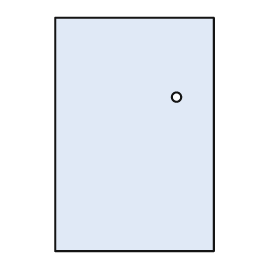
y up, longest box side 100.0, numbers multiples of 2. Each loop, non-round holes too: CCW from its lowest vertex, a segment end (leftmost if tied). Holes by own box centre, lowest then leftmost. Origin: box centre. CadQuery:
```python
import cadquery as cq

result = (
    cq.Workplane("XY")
    .moveTo(-34.0, -50.0)
    .lineTo(34.0, -50.0)
    .lineTo(34.0, 50.0)
    .lineTo(-34.0, 50.0)
    .close()
    .moveTo(18.0, 16.0)
    .circle(2.0)
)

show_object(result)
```